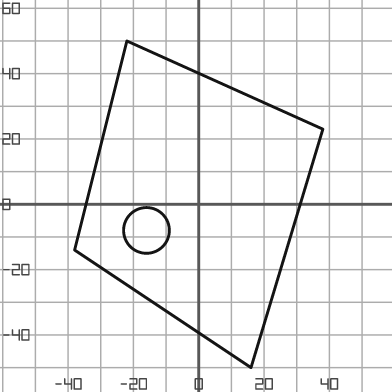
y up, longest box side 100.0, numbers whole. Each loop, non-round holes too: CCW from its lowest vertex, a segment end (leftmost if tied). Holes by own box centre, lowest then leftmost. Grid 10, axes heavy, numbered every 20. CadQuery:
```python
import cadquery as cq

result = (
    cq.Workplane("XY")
    .moveTo(16.0, -50.0)
    .lineTo(38.0, 23.0)
    .lineTo(-22.0, 50.0)
    .lineTo(-38.0, -14.0)
    .close()
    .moveTo(-16.0, -8.0)
    .circle(7.0)
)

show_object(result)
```